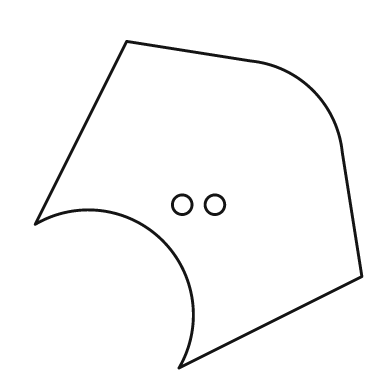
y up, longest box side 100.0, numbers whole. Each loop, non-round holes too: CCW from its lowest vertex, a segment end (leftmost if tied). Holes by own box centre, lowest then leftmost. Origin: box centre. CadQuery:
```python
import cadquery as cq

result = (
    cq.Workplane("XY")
    .moveTo(-6.0, -50.0)
    .lineTo(50.0, -22.0)
    .lineTo(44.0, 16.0)
    .threePointArc((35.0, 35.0), (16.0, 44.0))
    .lineTo(-22.0, 50.0)
    .lineTo(-50.0, -6.0)
    .threePointArc((-11.0, -11.0), (-6.0, -50.0))
    .close()
    .moveTo(-5.0, 0.0)
    .circle(3.0)
    .moveTo(5.0, 0.0)
    .circle(3.0)
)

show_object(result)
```